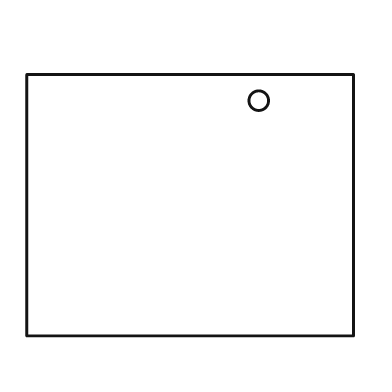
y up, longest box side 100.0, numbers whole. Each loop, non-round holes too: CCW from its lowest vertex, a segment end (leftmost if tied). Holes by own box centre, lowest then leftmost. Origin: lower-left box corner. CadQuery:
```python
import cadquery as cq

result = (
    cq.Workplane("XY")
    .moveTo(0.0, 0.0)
    .lineTo(100.0, 0.0)
    .lineTo(100.0, 80.0)
    .lineTo(0.0, 80.0)
    .close()
    .moveTo(71.0, 72.0)
    .circle(3.0)
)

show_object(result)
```